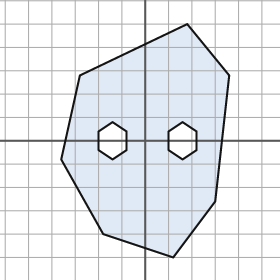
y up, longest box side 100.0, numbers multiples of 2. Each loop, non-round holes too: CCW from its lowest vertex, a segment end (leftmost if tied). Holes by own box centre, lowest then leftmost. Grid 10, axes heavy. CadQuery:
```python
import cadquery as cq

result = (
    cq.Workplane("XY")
    .moveTo(12.0, -50.0)
    .lineTo(30.0, -26.0)
    .lineTo(36.0, 28.0)
    .lineTo(18.0, 50.0)
    .lineTo(-28.0, 28.0)
    .lineTo(-36.0, -8.0)
    .lineTo(-18.0, -40.0)
    .close()
    .moveTo(-14.0, -8.0)
    .lineTo(-8.0, -4.0)
    .lineTo(-8.0, 4.0)
    .lineTo(-14.0, 8.0)
    .lineTo(-20.0, 4.0)
    .lineTo(-20.0, -4.0)
    .close()
    .moveTo(16.0, -8.0)
    .lineTo(22.0, -4.0)
    .lineTo(22.0, 4.0)
    .lineTo(16.0, 8.0)
    .lineTo(10.0, 4.0)
    .lineTo(10.0, -4.0)
    .close()
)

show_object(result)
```